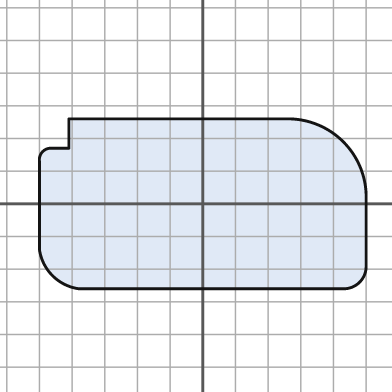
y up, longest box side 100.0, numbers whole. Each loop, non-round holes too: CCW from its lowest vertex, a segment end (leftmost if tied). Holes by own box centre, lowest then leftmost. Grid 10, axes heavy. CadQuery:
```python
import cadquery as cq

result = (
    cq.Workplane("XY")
    .moveTo(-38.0, -26.0)
    .lineTo(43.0, -26.0)
    .threePointArc((48.0, -24.0), (50.0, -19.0))
    .lineTo(50.0, 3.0)
    .threePointArc((43.0, 19.0), (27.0, 26.0))
    .lineTo(-41.0, 26.0)
    .lineTo(-41.0, 17.0)
    .lineTo(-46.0, 17.0)
    .threePointArc((-49.0, 16.0), (-50.0, 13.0))
    .lineTo(-50.0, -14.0)
    .threePointArc((-46.0, -22.0), (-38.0, -26.0))
    .close()
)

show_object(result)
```